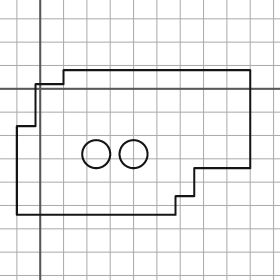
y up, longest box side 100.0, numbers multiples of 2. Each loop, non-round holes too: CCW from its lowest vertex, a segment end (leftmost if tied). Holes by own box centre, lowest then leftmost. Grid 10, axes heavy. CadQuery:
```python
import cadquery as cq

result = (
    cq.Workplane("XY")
    .moveTo(-10.0, -54.0)
    .lineTo(58.0, -54.0)
    .lineTo(58.0, -46.0)
    .lineTo(66.0, -46.0)
    .lineTo(66.0, -34.0)
    .lineTo(90.0, -34.0)
    .lineTo(90.0, 8.0)
    .lineTo(10.0, 8.0)
    .lineTo(10.0, 2.0)
    .lineTo(-2.0, 2.0)
    .lineTo(-2.0, -16.0)
    .lineTo(-10.0, -16.0)
    .close()
    .moveTo(24.0, -28.0)
    .circle(6.0)
    .moveTo(40.0, -28.0)
    .circle(6.0)
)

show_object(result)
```